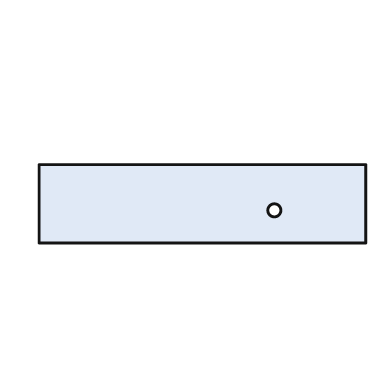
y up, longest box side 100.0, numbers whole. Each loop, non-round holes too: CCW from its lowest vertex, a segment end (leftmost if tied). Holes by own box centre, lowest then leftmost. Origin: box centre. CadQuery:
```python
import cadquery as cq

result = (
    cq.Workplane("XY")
    .moveTo(-50.0, -12.0)
    .lineTo(50.0, -12.0)
    .lineTo(50.0, 12.0)
    .lineTo(-50.0, 12.0)
    .close()
    .moveTo(22.0, -2.0)
    .circle(2.0)
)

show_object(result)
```